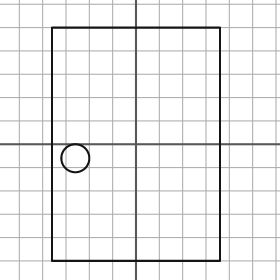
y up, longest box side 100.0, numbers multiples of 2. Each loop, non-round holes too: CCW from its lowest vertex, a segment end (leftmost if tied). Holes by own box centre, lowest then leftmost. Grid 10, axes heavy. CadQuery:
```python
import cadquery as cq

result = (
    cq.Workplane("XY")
    .moveTo(-36.0, -50.0)
    .lineTo(36.0, -50.0)
    .lineTo(36.0, 50.0)
    .lineTo(-36.0, 50.0)
    .close()
    .moveTo(-26.0, -6.0)
    .circle(6.0)
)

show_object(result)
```